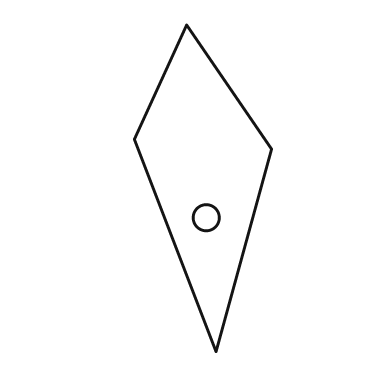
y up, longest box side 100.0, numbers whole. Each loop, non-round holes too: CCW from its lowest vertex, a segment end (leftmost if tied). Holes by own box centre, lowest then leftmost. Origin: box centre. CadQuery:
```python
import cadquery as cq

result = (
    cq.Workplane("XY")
    .moveTo(4.0, -50.0)
    .lineTo(21.0, 12.0)
    .lineTo(-5.0, 50.0)
    .lineTo(-21.0, 15.0)
    .close()
    .moveTo(1.0, -9.0)
    .circle(4.0)
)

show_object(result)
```